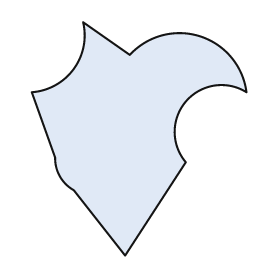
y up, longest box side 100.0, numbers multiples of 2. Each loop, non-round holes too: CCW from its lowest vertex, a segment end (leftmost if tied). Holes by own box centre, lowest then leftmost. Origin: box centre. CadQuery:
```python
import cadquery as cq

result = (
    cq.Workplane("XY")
    .moveTo(-6.0, -50.0)
    .lineTo(20.0, -10.0)
    .threePointArc((20.0, 16.0), (46.0, 20.0))
    .threePointArc((26.0, 44.0), (-4.0, 36.0))
    .lineTo(-24.0, 50.0)
    .threePointArc((-28.0, 30.0), (-46.0, 20.0))
    .lineTo(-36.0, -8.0)
    .threePointArc((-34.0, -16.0), (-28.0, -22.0))
    .close()
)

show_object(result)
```